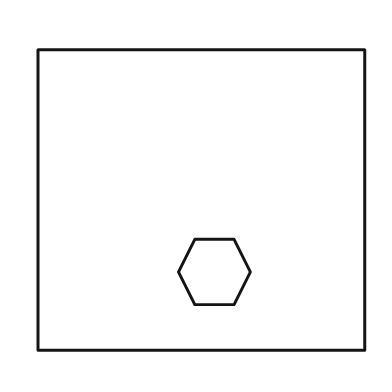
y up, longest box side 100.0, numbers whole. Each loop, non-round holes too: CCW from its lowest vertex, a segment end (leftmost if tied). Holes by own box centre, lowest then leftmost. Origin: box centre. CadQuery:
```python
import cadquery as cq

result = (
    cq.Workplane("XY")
    .moveTo(-50.0, -46.0)
    .lineTo(50.0, -46.0)
    .lineTo(50.0, 46.0)
    .lineTo(-50.0, 46.0)
    .close()
    .moveTo(-2.0, -32.0)
    .lineTo(10.0, -32.0)
    .lineTo(15.0, -22.0)
    .lineTo(10.0, -12.0)
    .lineTo(-2.0, -12.0)
    .lineTo(-7.0, -22.0)
    .close()
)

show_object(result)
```